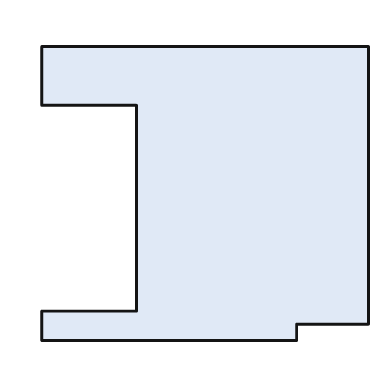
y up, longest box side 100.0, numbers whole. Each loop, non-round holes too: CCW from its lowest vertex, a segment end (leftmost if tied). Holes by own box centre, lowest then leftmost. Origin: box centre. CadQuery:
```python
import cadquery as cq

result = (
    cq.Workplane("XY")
    .moveTo(-50.0, -45.0)
    .lineTo(28.0, -45.0)
    .lineTo(28.0, -40.0)
    .lineTo(50.0, -40.0)
    .lineTo(50.0, 45.0)
    .lineTo(-50.0, 45.0)
    .lineTo(-50.0, 27.0)
    .lineTo(-21.0, 27.0)
    .lineTo(-21.0, -36.0)
    .lineTo(-50.0, -36.0)
    .close()
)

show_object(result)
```